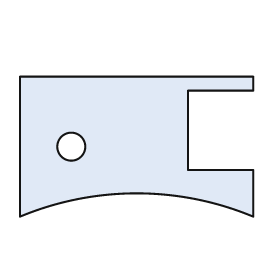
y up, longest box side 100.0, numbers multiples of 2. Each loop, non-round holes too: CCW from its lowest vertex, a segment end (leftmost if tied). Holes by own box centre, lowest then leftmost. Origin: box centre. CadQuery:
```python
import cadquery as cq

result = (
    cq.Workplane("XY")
    .moveTo(-50.0, -30.0)
    .threePointArc((0.0, -20.0), (50.0, -30.0))
    .lineTo(50.0, -10.0)
    .lineTo(22.0, -10.0)
    .lineTo(22.0, 24.0)
    .lineTo(50.0, 24.0)
    .lineTo(50.0, 30.0)
    .lineTo(-50.0, 30.0)
    .close()
    .moveTo(-28.0, 0.0)
    .circle(6.0)
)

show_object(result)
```